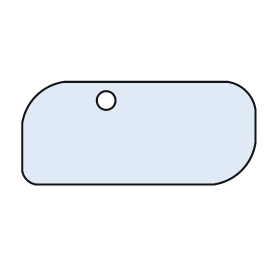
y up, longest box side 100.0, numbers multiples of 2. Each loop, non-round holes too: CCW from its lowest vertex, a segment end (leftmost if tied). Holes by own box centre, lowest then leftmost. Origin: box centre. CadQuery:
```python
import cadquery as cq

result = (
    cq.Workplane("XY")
    .moveTo(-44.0, -22.0)
    .lineTo(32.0, -22.0)
    .threePointArc((44.0, -16.0), (50.0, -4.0))
    .lineTo(50.0, 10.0)
    .threePointArc((46.0, 18.0), (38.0, 22.0))
    .lineTo(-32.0, 22.0)
    .threePointArc((-44.0, 16.0), (-50.0, 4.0))
    .lineTo(-50.0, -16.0)
    .threePointArc((-48.0, -20.0), (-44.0, -22.0))
    .close()
    .moveTo(-14.0, 14.0)
    .circle(4.0)
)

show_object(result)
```